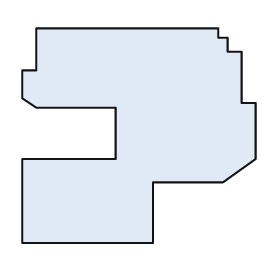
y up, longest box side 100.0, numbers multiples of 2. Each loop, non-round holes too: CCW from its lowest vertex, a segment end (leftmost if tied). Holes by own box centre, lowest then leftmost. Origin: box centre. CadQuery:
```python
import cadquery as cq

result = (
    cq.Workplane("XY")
    .moveTo(-50.0, -46.0)
    .lineTo(6.0, -46.0)
    .lineTo(6.0, -20.0)
    .lineTo(36.0, -20.0)
    .lineTo(50.0, -10.0)
    .lineTo(50.0, 14.0)
    .lineTo(44.0, 14.0)
    .lineTo(44.0, 36.0)
    .lineTo(38.0, 36.0)
    .lineTo(38.0, 42.0)
    .lineTo(34.0, 42.0)
    .lineTo(34.0, 46.0)
    .lineTo(-44.0, 46.0)
    .lineTo(-44.0, 28.0)
    .lineTo(-50.0, 28.0)
    .lineTo(-50.0, 16.0)
    .lineTo(-44.0, 12.0)
    .lineTo(-10.0, 12.0)
    .lineTo(-10.0, -10.0)
    .lineTo(-50.0, -10.0)
    .close()
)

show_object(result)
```